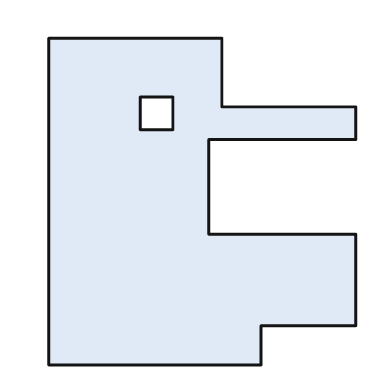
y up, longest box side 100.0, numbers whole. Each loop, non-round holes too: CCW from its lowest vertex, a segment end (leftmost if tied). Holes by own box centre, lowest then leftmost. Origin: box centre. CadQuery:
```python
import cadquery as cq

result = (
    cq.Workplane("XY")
    .moveTo(-47.0, -50.0)
    .lineTo(18.0, -50.0)
    .lineTo(18.0, -38.0)
    .lineTo(47.0, -38.0)
    .lineTo(47.0, -10.0)
    .lineTo(2.0, -10.0)
    .lineTo(2.0, 19.0)
    .lineTo(47.0, 19.0)
    .lineTo(47.0, 29.0)
    .lineTo(6.0, 29.0)
    .lineTo(6.0, 50.0)
    .lineTo(-47.0, 50.0)
    .close()
    .moveTo(-19.0, 22.0)
    .lineTo(-9.0, 22.0)
    .lineTo(-9.0, 32.0)
    .lineTo(-19.0, 32.0)
    .close()
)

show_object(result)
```